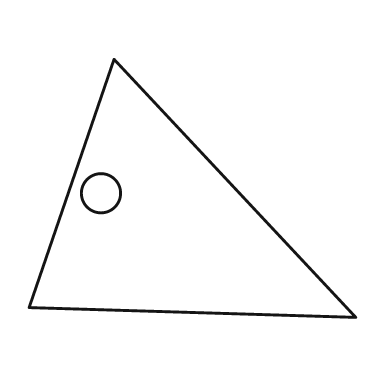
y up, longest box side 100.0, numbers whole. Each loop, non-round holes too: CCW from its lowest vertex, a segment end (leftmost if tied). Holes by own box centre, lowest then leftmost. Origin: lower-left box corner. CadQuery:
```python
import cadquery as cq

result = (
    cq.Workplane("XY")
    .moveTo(100.0, 0.0)
    .lineTo(26.0, 79.0)
    .lineTo(0.0, 3.0)
    .close()
    .moveTo(22.0, 38.0)
    .circle(6.0)
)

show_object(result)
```